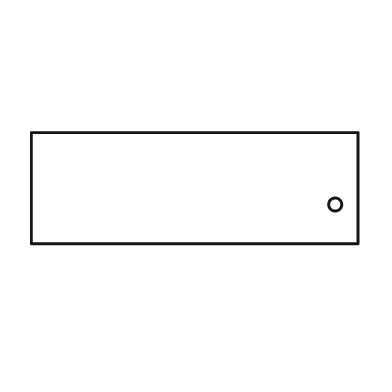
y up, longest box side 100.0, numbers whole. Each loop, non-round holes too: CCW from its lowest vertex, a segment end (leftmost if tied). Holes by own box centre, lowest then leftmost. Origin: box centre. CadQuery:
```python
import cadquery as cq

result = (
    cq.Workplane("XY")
    .moveTo(-50.0, -17.0)
    .lineTo(50.0, -17.0)
    .lineTo(50.0, 17.0)
    .lineTo(-50.0, 17.0)
    .close()
    .moveTo(43.0, -5.0)
    .circle(2.0)
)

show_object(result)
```